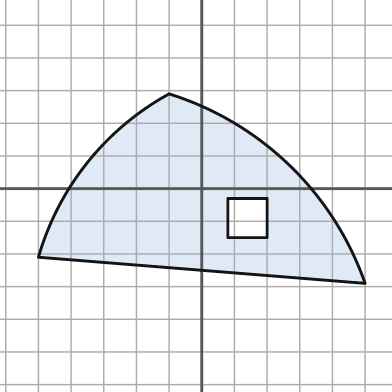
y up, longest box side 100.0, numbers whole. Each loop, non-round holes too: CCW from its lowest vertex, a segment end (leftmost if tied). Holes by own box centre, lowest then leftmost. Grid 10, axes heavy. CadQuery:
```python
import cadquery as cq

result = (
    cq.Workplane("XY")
    .moveTo(50.0, -29.0)
    .threePointArc((27.0, 7.0), (-10.0, 29.0))
    .threePointArc((-35.0, 8.0), (-50.0, -21.0))
    .close()
    .moveTo(8.0, -15.0)
    .lineTo(20.0, -15.0)
    .lineTo(20.0, -3.0)
    .lineTo(8.0, -3.0)
    .close()
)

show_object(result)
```